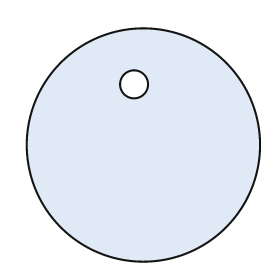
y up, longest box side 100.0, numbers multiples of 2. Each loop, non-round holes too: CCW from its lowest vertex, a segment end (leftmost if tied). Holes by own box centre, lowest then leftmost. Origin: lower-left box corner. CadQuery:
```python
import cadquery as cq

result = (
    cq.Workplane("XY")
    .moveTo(50.0, 50.0)
    .circle(50.0)
    .moveTo(46.0, 76.0)
    .circle(6.0)
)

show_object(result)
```